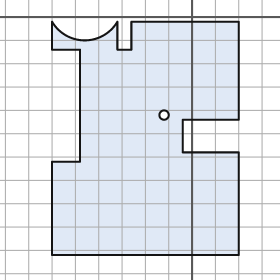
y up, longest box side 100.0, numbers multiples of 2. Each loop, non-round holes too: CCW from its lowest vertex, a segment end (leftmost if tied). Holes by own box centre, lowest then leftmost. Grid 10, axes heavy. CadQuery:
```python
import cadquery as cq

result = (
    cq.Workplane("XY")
    .moveTo(-60.0, -102.0)
    .lineTo(20.0, -102.0)
    .lineTo(20.0, -58.0)
    .lineTo(-4.0, -58.0)
    .lineTo(-4.0, -44.0)
    .lineTo(20.0, -44.0)
    .lineTo(20.0, -2.0)
    .lineTo(-26.0, -2.0)
    .lineTo(-26.0, -14.0)
    .lineTo(-32.0, -14.0)
    .lineTo(-32.0, -2.0)
    .threePointArc((-46.0, -10.0), (-60.0, -2.0))
    .lineTo(-60.0, -14.0)
    .lineTo(-48.0, -14.0)
    .lineTo(-48.0, -62.0)
    .lineTo(-60.0, -62.0)
    .close()
    .moveTo(-12.0, -42.0)
    .circle(2.0)
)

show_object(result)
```